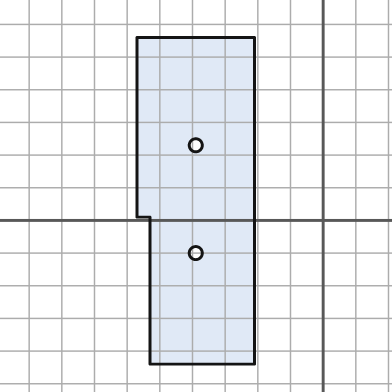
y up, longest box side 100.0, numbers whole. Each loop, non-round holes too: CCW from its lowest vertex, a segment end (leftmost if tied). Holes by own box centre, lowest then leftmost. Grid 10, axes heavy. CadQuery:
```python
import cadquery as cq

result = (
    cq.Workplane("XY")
    .moveTo(-53.0, -44.0)
    .lineTo(-21.0, -44.0)
    .lineTo(-21.0, 56.0)
    .lineTo(-57.0, 56.0)
    .lineTo(-57.0, 1.0)
    .lineTo(-53.0, 1.0)
    .close()
    .moveTo(-39.0, -10.0)
    .circle(2.0)
    .moveTo(-39.0, 23.0)
    .circle(2.0)
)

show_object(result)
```